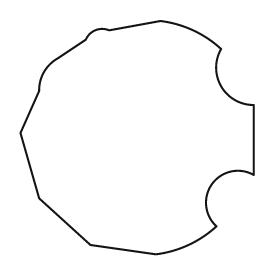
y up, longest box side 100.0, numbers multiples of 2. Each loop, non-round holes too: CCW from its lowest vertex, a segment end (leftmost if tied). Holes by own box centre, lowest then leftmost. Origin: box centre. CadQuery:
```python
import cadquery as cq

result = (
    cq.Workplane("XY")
    .moveTo(8.0, -50.0)
    .threePointArc((22.0, -46.0), (34.0, -38.0))
    .threePointArc((32.0, -20.0), (50.0, -16.0))
    .lineTo(50.0, 14.0)
    .threePointArc((36.0, 22.0), (36.0, 38.0))
    .threePointArc((24.0, 46.0), (10.0, 50.0))
    .lineTo(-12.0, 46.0)
    .threePointArc((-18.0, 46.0), (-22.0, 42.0))
    .lineTo(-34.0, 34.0)
    .threePointArc((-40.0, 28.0), (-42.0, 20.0))
    .lineTo(-50.0, 2.0)
    .lineTo(-42.0, -26.0)
    .lineTo(-20.0, -46.0)
    .close()
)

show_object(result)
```